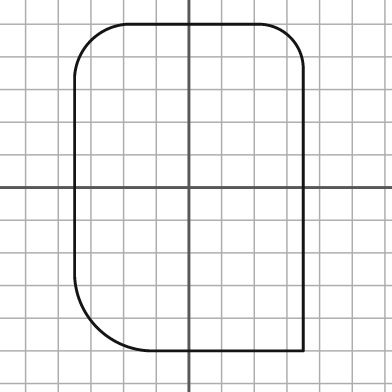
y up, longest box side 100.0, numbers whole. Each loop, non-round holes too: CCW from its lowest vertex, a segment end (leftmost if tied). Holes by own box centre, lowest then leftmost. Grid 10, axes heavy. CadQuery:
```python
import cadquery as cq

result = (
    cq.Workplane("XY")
    .moveTo(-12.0, -50.0)
    .lineTo(35.0, -50.0)
    .lineTo(35.0, 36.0)
    .threePointArc((31.0, 46.0), (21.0, 50.0))
    .lineTo(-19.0, 50.0)
    .threePointArc((-30.0, 45.0), (-35.0, 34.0))
    .lineTo(-35.0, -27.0)
    .threePointArc((-28.0, -43.0), (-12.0, -50.0))
    .close()
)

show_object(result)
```